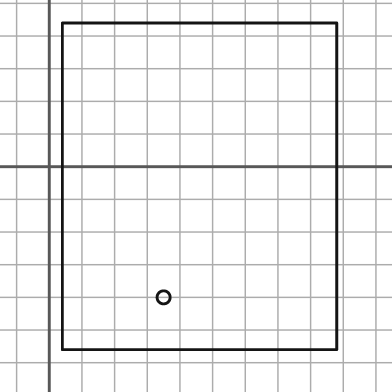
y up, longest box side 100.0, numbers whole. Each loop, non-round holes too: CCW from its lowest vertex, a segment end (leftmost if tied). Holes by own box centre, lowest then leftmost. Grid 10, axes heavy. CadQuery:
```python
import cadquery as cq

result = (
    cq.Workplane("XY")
    .moveTo(4.0, -56.0)
    .lineTo(88.0, -56.0)
    .lineTo(88.0, 44.0)
    .lineTo(4.0, 44.0)
    .close()
    .moveTo(35.0, -40.0)
    .circle(2.0)
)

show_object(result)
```